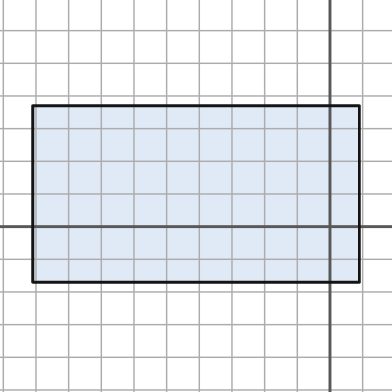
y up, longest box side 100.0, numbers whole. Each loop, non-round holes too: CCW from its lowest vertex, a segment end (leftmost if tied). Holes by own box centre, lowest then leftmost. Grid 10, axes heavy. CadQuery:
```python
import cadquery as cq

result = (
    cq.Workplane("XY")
    .moveTo(-91.0, -17.0)
    .lineTo(9.0, -17.0)
    .lineTo(9.0, 37.0)
    .lineTo(-91.0, 37.0)
    .close()
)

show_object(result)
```